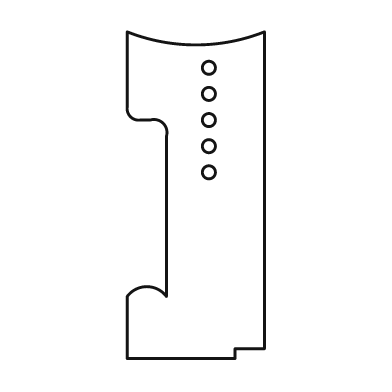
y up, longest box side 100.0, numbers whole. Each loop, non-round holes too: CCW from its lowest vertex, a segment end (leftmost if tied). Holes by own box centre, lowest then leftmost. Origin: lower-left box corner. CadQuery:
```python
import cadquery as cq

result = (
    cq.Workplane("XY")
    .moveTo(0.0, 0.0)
    .lineTo(33.0, 0.0)
    .lineTo(33.0, 3.0)
    .lineTo(42.0, 3.0)
    .lineTo(42.0, 100.0)
    .threePointArc((21.0, 96.0), (0.0, 100.0))
    .lineTo(0.0, 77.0)
    .threePointArc((1.0, 74.0), (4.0, 73.0))
    .lineTo(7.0, 73.0)
    .threePointArc((11.0, 72.0), (12.0, 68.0))
    .lineTo(12.0, 19.0)
    .threePointArc((6.0, 22.0), (0.0, 19.0))
    .close()
    .moveTo(25.0, 57.0)
    .circle(2.0)
    .moveTo(25.0, 65.0)
    .circle(2.0)
    .moveTo(25.0, 73.0)
    .circle(2.0)
    .moveTo(25.0, 81.0)
    .circle(2.0)
    .moveTo(25.0, 89.0)
    .circle(2.0)
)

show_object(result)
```